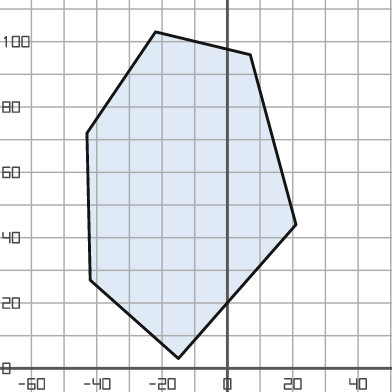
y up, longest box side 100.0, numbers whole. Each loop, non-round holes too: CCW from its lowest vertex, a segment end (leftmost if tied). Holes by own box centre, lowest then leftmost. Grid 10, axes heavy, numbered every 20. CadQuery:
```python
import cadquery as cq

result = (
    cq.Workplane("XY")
    .moveTo(-15.0, 3.0)
    .lineTo(21.0, 44.0)
    .lineTo(7.0, 96.0)
    .lineTo(-22.0, 103.0)
    .lineTo(-43.0, 72.0)
    .lineTo(-42.0, 27.0)
    .close()
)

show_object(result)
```